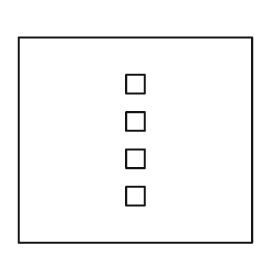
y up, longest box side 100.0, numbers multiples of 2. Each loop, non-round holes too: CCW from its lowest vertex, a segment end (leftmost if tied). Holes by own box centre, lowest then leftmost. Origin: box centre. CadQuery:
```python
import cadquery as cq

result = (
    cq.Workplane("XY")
    .moveTo(-50.0, -44.0)
    .lineTo(50.0, -44.0)
    .lineTo(50.0, 44.0)
    .lineTo(-50.0, 44.0)
    .close()
    .moveTo(-4.0, -28.0)
    .lineTo(4.0, -28.0)
    .lineTo(4.0, -20.0)
    .lineTo(-4.0, -20.0)
    .close()
    .moveTo(-4.0, -12.0)
    .lineTo(4.0, -12.0)
    .lineTo(4.0, -4.0)
    .lineTo(-4.0, -4.0)
    .close()
    .moveTo(-4.0, 4.0)
    .lineTo(4.0, 4.0)
    .lineTo(4.0, 12.0)
    .lineTo(-4.0, 12.0)
    .close()
    .moveTo(-4.0, 20.0)
    .lineTo(4.0, 20.0)
    .lineTo(4.0, 28.0)
    .lineTo(-4.0, 28.0)
    .close()
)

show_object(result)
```